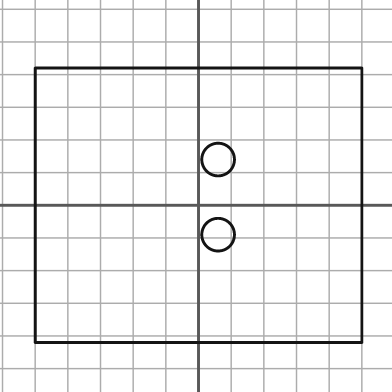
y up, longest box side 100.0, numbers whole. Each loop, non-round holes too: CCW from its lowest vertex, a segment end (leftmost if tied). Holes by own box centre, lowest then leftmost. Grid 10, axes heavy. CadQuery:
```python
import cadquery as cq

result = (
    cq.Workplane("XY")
    .moveTo(-50.0, -42.0)
    .lineTo(50.0, -42.0)
    .lineTo(50.0, 42.0)
    .lineTo(-50.0, 42.0)
    .close()
    .moveTo(6.0, -9.0)
    .circle(5.0)
    .moveTo(6.0, 14.0)
    .circle(5.0)
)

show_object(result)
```